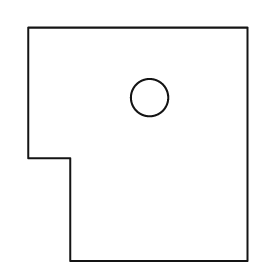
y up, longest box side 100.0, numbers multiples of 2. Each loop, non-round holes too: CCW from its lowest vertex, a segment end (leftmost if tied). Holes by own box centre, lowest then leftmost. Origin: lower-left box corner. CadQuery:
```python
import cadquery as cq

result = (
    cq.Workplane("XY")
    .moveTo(18.0, 0.0)
    .lineTo(94.0, 0.0)
    .lineTo(94.0, 100.0)
    .lineTo(0.0, 100.0)
    .lineTo(0.0, 44.0)
    .lineTo(18.0, 44.0)
    .close()
    .moveTo(52.0, 70.0)
    .circle(8.0)
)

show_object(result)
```